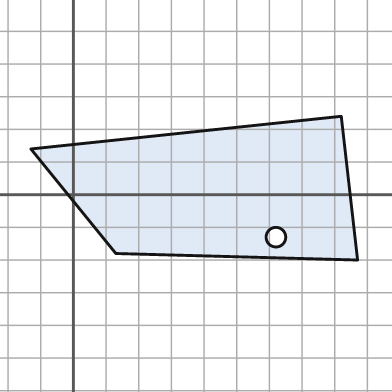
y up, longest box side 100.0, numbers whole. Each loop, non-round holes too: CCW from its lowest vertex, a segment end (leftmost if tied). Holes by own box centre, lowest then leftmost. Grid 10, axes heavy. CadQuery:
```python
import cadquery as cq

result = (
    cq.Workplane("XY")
    .moveTo(87.0, -20.0)
    .lineTo(82.0, 24.0)
    .lineTo(-13.0, 14.0)
    .lineTo(13.0, -18.0)
    .close()
    .moveTo(62.0, -13.0)
    .circle(3.0)
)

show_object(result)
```